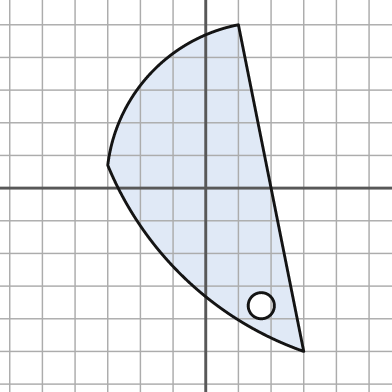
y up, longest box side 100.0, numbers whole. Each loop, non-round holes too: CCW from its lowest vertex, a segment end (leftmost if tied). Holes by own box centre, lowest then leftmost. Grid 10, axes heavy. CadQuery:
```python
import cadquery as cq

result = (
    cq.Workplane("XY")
    .moveTo(30.0, -50.0)
    .lineTo(10.0, 50.0)
    .threePointArc((-17.0, 35.0), (-30.0, 7.0))
    .threePointArc((-6.0, -28.0), (30.0, -50.0))
    .close()
    .moveTo(17.0, -36.0)
    .circle(4.0)
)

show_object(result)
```